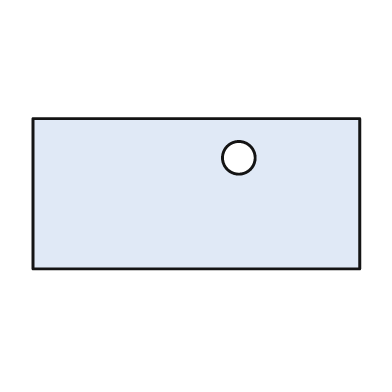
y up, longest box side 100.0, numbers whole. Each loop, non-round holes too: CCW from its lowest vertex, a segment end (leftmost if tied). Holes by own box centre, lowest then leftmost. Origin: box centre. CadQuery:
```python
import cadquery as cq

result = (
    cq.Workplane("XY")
    .moveTo(-50.0, -23.0)
    .lineTo(50.0, -23.0)
    .lineTo(50.0, 23.0)
    .lineTo(-50.0, 23.0)
    .close()
    .moveTo(13.0, 11.0)
    .circle(5.0)
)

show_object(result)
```